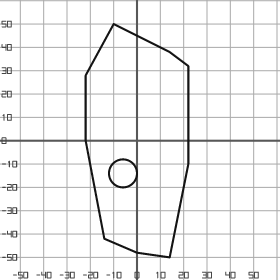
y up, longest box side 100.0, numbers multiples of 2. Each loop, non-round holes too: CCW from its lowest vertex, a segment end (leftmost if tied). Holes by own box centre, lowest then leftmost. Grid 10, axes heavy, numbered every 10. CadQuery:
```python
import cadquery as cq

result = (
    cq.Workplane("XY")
    .moveTo(14.0, -50.0)
    .lineTo(22.0, -10.0)
    .lineTo(22.0, 32.0)
    .lineTo(14.0, 38.0)
    .lineTo(-10.0, 50.0)
    .lineTo(-22.0, 28.0)
    .lineTo(-22.0, 0.0)
    .lineTo(-14.0, -42.0)
    .lineTo(0.0, -48.0)
    .close()
    .moveTo(-6.0, -14.0)
    .circle(6.0)
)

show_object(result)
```